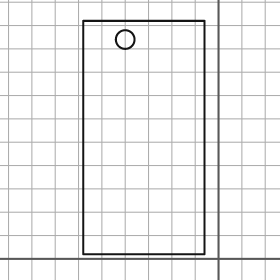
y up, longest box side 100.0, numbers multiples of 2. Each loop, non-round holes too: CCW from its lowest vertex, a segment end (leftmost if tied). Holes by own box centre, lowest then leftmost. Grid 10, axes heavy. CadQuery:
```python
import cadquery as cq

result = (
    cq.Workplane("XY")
    .moveTo(-58.0, 2.0)
    .lineTo(-6.0, 2.0)
    .lineTo(-6.0, 102.0)
    .lineTo(-58.0, 102.0)
    .close()
    .moveTo(-40.0, 94.0)
    .circle(4.0)
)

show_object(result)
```